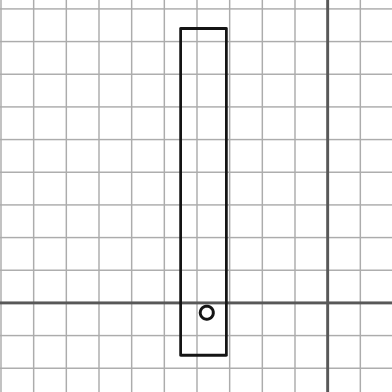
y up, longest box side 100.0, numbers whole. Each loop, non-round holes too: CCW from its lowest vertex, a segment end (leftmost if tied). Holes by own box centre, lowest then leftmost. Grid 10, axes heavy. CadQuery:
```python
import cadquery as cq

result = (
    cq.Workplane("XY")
    .moveTo(-45.0, -16.0)
    .lineTo(-31.0, -16.0)
    .lineTo(-31.0, 84.0)
    .lineTo(-45.0, 84.0)
    .close()
    .moveTo(-37.0, -3.0)
    .circle(2.0)
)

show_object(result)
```